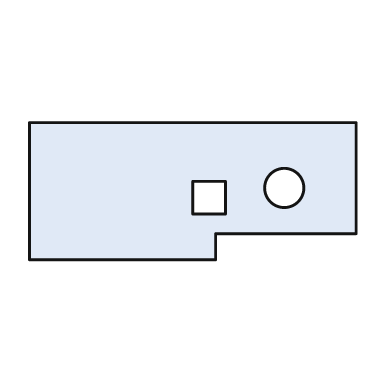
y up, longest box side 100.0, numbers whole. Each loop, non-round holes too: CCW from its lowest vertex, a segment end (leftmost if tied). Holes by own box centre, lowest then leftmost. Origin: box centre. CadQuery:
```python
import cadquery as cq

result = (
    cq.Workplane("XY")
    .moveTo(-50.0, -21.0)
    .lineTo(7.0, -21.0)
    .lineTo(7.0, -13.0)
    .lineTo(50.0, -13.0)
    .lineTo(50.0, 21.0)
    .lineTo(-50.0, 21.0)
    .close()
    .moveTo(0.0, -7.0)
    .lineTo(10.0, -7.0)
    .lineTo(10.0, 3.0)
    .lineTo(0.0, 3.0)
    .close()
    .moveTo(28.0, 1.0)
    .circle(6.0)
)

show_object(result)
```